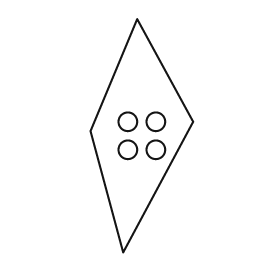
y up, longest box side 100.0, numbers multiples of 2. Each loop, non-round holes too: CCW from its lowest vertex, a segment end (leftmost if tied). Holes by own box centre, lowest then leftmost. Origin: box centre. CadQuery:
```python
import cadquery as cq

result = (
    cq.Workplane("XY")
    .moveTo(-8.0, -50.0)
    .lineTo(22.0, 6.0)
    .lineTo(-2.0, 50.0)
    .lineTo(-22.0, 2.0)
    .close()
    .moveTo(-6.0, -6.0)
    .circle(4.0)
    .moveTo(6.0, -6.0)
    .circle(4.0)
    .moveTo(-6.0, 6.0)
    .circle(4.0)
    .moveTo(6.0, 6.0)
    .circle(4.0)
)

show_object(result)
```